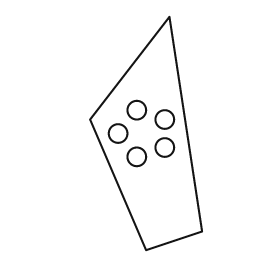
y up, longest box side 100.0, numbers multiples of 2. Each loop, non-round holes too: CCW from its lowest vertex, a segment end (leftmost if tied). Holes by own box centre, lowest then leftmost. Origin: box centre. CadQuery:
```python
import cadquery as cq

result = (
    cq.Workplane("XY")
    .moveTo(0.0, -50.0)
    .lineTo(24.0, -42.0)
    .lineTo(10.0, 50.0)
    .lineTo(-24.0, 6.0)
    .close()
    .moveTo(-4.0, -10.0)
    .circle(4.0)
    .moveTo(8.0, -6.0)
    .circle(4.0)
    .moveTo(-12.0, 0.0)
    .circle(4.0)
    .moveTo(8.0, 6.0)
    .circle(4.0)
    .moveTo(-4.0, 10.0)
    .circle(4.0)
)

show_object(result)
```